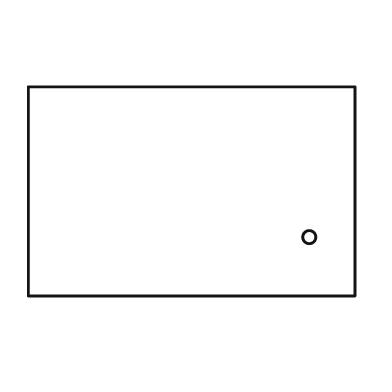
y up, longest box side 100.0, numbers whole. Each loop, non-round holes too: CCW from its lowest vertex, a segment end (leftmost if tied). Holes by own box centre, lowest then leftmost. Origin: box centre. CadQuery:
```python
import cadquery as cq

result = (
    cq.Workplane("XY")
    .moveTo(-50.0, -32.0)
    .lineTo(50.0, -32.0)
    .lineTo(50.0, 32.0)
    .lineTo(-50.0, 32.0)
    .close()
    .moveTo(36.0, -14.0)
    .circle(2.0)
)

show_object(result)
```